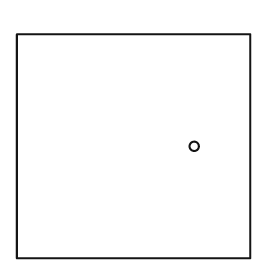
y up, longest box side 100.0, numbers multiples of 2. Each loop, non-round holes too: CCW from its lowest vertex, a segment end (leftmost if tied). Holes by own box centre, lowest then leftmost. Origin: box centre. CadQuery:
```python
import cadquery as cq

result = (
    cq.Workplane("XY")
    .moveTo(-50.0, -48.0)
    .lineTo(50.0, -48.0)
    .lineTo(50.0, 48.0)
    .lineTo(-50.0, 48.0)
    .close()
    .moveTo(26.0, 0.0)
    .circle(2.0)
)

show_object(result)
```